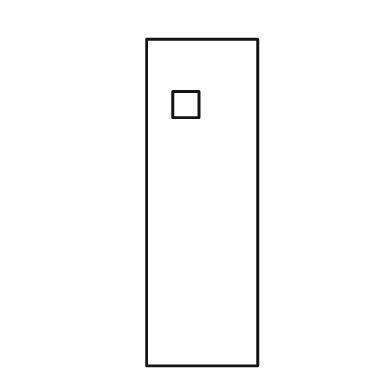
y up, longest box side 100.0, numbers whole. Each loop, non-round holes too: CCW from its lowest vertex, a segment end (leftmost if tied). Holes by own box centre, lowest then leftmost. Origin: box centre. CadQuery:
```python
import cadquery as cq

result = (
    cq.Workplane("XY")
    .moveTo(-17.0, -50.0)
    .lineTo(17.0, -50.0)
    .lineTo(17.0, 50.0)
    .lineTo(-17.0, 50.0)
    .close()
    .moveTo(-9.0, 26.0)
    .lineTo(-1.0, 26.0)
    .lineTo(-1.0, 34.0)
    .lineTo(-9.0, 34.0)
    .close()
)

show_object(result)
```